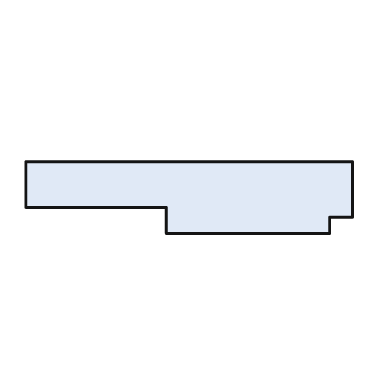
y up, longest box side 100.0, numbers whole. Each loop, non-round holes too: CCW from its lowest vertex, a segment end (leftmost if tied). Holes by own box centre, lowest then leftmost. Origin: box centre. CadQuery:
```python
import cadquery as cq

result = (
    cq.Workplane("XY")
    .moveTo(-7.0, -11.0)
    .lineTo(43.0, -11.0)
    .lineTo(43.0, -6.0)
    .lineTo(50.0, -6.0)
    .lineTo(50.0, 11.0)
    .lineTo(-50.0, 11.0)
    .lineTo(-50.0, -3.0)
    .lineTo(-7.0, -3.0)
    .close()
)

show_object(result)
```